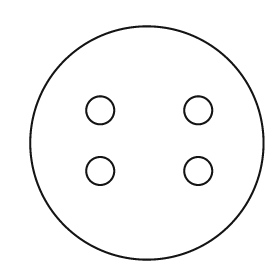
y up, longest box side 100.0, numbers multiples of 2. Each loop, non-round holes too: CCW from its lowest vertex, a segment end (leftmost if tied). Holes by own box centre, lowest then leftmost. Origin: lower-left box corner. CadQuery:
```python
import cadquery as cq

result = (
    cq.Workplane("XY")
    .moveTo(50.0, 50.0)
    .circle(50.0)
    .moveTo(30.0, 38.0)
    .circle(6.0)
    .moveTo(72.0, 38.0)
    .circle(6.0)
    .moveTo(30.0, 64.0)
    .circle(6.0)
    .moveTo(72.0, 64.0)
    .circle(6.0)
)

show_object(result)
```